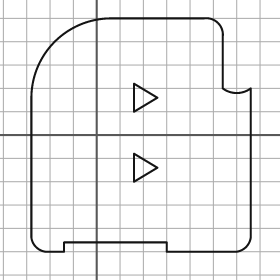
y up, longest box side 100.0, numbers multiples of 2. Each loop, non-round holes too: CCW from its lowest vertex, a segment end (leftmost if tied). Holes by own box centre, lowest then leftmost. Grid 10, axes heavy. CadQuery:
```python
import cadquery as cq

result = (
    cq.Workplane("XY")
    .moveTo(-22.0, -50.0)
    .lineTo(-14.0, -50.0)
    .lineTo(-14.0, -46.0)
    .lineTo(30.0, -46.0)
    .lineTo(30.0, -50.0)
    .lineTo(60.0, -50.0)
    .threePointArc((64.0, -48.0), (66.0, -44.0))
    .lineTo(66.0, 20.0)
    .threePointArc((60.0, 18.0), (54.0, 20.0))
    .lineTo(54.0, 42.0)
    .threePointArc((52.0, 48.0), (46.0, 50.0))
    .lineTo(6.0, 50.0)
    .threePointArc((-18.0, 40.0), (-28.0, 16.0))
    .lineTo(-28.0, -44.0)
    .threePointArc((-26.0, -48.0), (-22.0, -50.0))
    .close()
    .moveTo(16.0, -20.0)
    .lineTo(26.0, -14.0)
    .lineTo(16.0, -8.0)
    .close()
    .moveTo(16.0, 10.0)
    .lineTo(26.0, 16.0)
    .lineTo(16.0, 22.0)
    .close()
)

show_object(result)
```